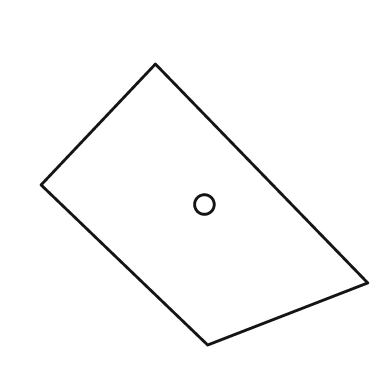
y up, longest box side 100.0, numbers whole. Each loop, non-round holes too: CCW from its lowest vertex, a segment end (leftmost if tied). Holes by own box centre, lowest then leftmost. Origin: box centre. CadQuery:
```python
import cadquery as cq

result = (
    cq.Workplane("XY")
    .moveTo(1.0, -43.0)
    .lineTo(50.0, -24.0)
    .lineTo(-15.0, 43.0)
    .lineTo(-50.0, 6.0)
    .close()
    .moveTo(0.0, 0.0)
    .circle(3.0)
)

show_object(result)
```